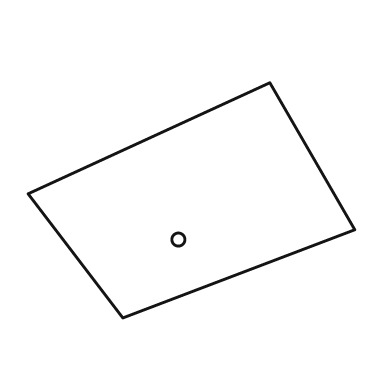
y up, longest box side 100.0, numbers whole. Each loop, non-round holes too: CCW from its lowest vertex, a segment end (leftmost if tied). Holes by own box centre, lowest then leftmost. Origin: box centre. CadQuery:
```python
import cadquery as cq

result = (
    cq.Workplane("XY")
    .moveTo(-21.0, -36.0)
    .lineTo(50.0, -9.0)
    .lineTo(24.0, 36.0)
    .lineTo(-50.0, 2.0)
    .close()
    .moveTo(-4.0, -12.0)
    .circle(2.0)
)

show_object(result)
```